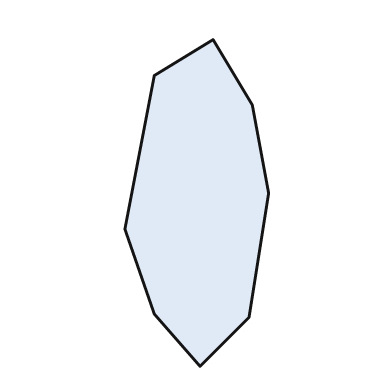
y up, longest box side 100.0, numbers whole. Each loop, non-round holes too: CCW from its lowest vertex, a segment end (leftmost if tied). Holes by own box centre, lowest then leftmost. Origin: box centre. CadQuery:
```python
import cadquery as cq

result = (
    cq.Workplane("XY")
    .moveTo(1.0, -50.0)
    .lineTo(16.0, -35.0)
    .lineTo(22.0, 3.0)
    .lineTo(17.0, 30.0)
    .lineTo(5.0, 50.0)
    .lineTo(-13.0, 39.0)
    .lineTo(-22.0, -8.0)
    .lineTo(-13.0, -34.0)
    .close()
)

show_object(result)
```